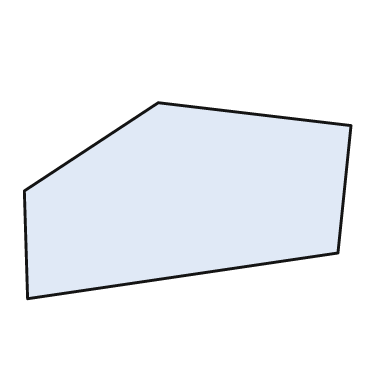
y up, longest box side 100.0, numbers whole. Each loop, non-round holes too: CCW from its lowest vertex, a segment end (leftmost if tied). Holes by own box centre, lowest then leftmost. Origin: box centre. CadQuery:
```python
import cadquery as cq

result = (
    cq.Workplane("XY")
    .moveTo(-49.0, -30.0)
    .lineTo(46.0, -16.0)
    .lineTo(50.0, 23.0)
    .lineTo(-9.0, 30.0)
    .lineTo(-50.0, 3.0)
    .close()
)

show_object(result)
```